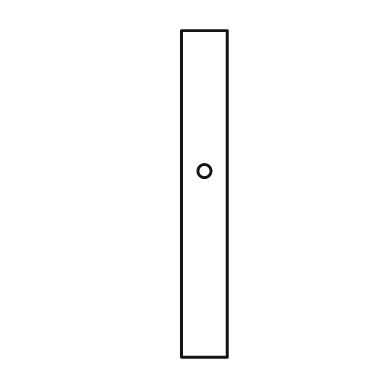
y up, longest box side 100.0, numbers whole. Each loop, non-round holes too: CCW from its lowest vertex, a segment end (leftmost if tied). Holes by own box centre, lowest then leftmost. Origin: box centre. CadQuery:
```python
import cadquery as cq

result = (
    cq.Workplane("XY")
    .moveTo(-7.0, -50.0)
    .lineTo(7.0, -50.0)
    .lineTo(7.0, 50.0)
    .lineTo(-7.0, 50.0)
    .close()
    .moveTo(0.0, 7.0)
    .circle(2.0)
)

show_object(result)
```